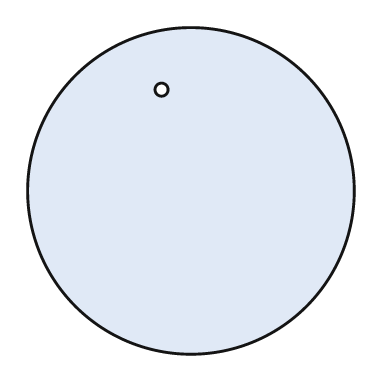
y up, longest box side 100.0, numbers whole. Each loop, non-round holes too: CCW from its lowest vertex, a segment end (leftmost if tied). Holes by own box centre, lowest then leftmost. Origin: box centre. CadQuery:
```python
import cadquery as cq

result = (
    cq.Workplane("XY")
    .moveTo(0.0, 0.0)
    .circle(50.0)
    .moveTo(-9.0, 31.0)
    .circle(2.0)
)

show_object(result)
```